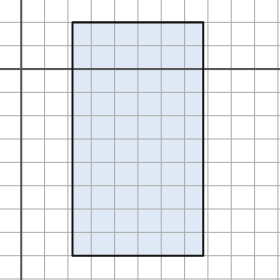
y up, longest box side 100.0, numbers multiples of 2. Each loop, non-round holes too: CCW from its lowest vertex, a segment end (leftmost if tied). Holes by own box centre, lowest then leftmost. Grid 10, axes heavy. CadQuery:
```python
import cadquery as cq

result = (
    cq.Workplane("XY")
    .moveTo(22.0, -80.0)
    .lineTo(78.0, -80.0)
    .lineTo(78.0, 20.0)
    .lineTo(22.0, 20.0)
    .close()
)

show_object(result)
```